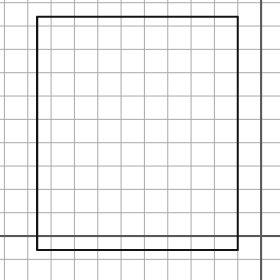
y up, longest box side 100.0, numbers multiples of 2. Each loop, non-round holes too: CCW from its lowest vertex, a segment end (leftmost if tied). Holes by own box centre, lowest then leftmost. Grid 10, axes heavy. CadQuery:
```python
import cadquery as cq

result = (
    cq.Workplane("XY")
    .moveTo(-96.0, -6.0)
    .lineTo(-10.0, -6.0)
    .lineTo(-10.0, 94.0)
    .lineTo(-96.0, 94.0)
    .close()
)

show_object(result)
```